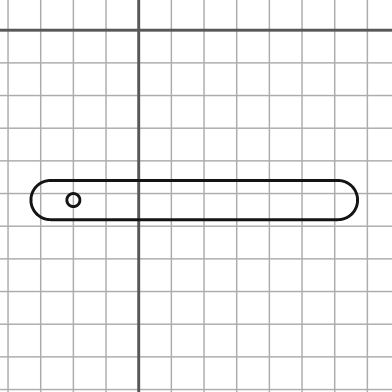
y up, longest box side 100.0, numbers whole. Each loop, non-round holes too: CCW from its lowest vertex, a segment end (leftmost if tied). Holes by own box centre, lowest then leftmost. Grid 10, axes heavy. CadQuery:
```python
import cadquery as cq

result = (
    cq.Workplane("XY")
    .moveTo(-27.0, -58.0)
    .lineTo(61.0, -58.0)
    .threePointArc((67.0, -52.0), (61.0, -46.0))
    .lineTo(-27.0, -46.0)
    .threePointArc((-33.0, -52.0), (-27.0, -58.0))
    .close()
    .moveTo(-20.0, -52.0)
    .circle(2.0)
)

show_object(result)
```